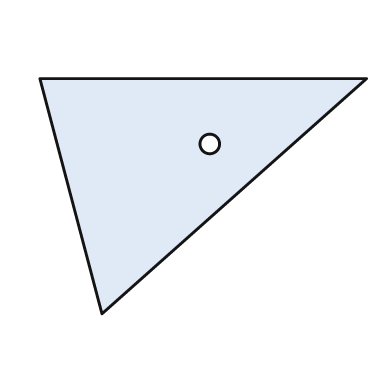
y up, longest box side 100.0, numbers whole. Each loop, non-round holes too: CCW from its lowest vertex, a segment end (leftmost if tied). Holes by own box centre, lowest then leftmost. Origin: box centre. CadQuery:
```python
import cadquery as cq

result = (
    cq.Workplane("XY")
    .moveTo(-31.0, -36.0)
    .lineTo(50.0, 36.0)
    .lineTo(-50.0, 36.0)
    .close()
    .moveTo(2.0, 16.0)
    .circle(3.0)
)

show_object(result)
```